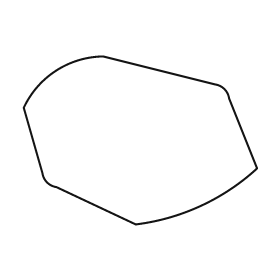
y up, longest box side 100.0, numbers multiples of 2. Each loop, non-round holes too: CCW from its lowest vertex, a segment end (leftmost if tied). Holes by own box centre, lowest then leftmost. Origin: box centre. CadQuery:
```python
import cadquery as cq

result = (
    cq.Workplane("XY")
    .moveTo(-2.0, -36.0)
    .threePointArc((26.0, -28.0), (50.0, -12.0))
    .lineTo(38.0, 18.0)
    .threePointArc((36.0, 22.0), (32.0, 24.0))
    .lineTo(-16.0, 36.0)
    .threePointArc((-36.0, 30.0), (-50.0, 14.0))
    .lineTo(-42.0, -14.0)
    .threePointArc((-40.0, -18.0), (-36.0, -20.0))
    .close()
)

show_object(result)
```